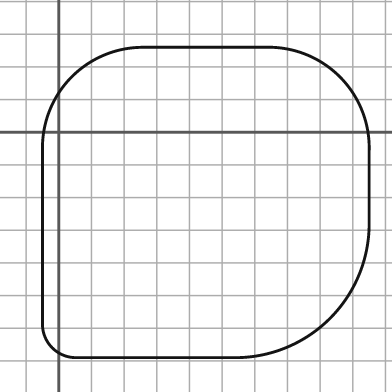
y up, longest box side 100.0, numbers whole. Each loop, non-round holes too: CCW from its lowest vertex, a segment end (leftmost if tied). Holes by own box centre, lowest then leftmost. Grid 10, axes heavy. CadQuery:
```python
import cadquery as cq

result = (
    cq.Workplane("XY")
    .moveTo(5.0, -69.0)
    .lineTo(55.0, -69.0)
    .threePointArc((83.0, -57.0), (95.0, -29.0))
    .lineTo(95.0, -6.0)
    .threePointArc((86.0, 17.0), (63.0, 26.0))
    .lineTo(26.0, 26.0)
    .threePointArc((4.0, 17.0), (-5.0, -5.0))
    .lineTo(-5.0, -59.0)
    .threePointArc((-2.0, -66.0), (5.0, -69.0))
    .close()
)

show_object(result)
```